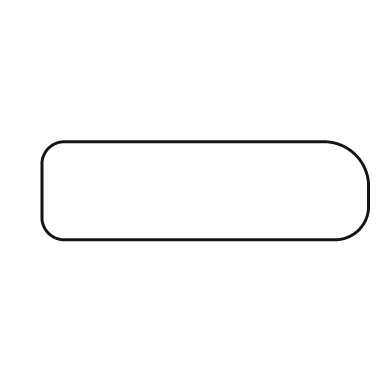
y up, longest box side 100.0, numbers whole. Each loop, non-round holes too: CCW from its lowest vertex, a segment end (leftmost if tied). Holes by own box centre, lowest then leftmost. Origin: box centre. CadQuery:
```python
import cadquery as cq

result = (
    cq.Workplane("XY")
    .moveTo(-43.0, -15.0)
    .lineTo(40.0, -15.0)
    .threePointArc((47.0, -12.0), (50.0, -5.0))
    .lineTo(50.0, 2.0)
    .threePointArc((46.0, 11.0), (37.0, 15.0))
    .lineTo(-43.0, 15.0)
    .threePointArc((-48.0, 13.0), (-50.0, 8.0))
    .lineTo(-50.0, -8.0)
    .threePointArc((-48.0, -13.0), (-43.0, -15.0))
    .close()
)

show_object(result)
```